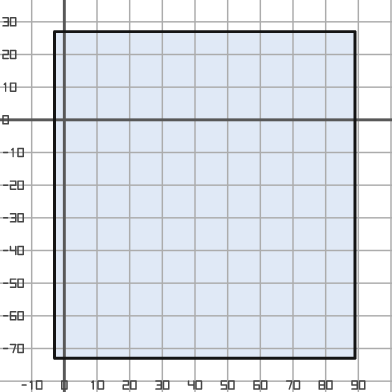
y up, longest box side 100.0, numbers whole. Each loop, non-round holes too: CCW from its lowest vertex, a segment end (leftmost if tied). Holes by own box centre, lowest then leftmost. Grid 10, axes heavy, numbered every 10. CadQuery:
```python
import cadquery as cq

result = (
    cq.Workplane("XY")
    .moveTo(-3.0, -73.0)
    .lineTo(89.0, -73.0)
    .lineTo(89.0, 27.0)
    .lineTo(-3.0, 27.0)
    .close()
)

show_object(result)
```